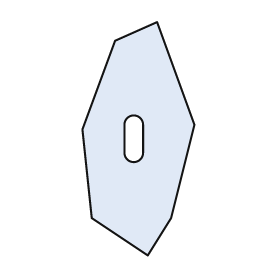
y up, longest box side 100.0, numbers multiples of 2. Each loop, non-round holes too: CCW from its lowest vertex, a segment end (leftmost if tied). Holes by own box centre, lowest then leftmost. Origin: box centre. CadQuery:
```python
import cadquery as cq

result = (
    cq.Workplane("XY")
    .moveTo(4.0, -50.0)
    .lineTo(14.0, -34.0)
    .lineTo(24.0, 6.0)
    .lineTo(8.0, 50.0)
    .lineTo(-10.0, 42.0)
    .lineTo(-24.0, 4.0)
    .lineTo(-20.0, -34.0)
    .close()
    .moveTo(-6.0, -6.0)
    .threePointArc((-2.0, -10.0), (2.0, -6.0))
    .lineTo(2.0, 6.0)
    .threePointArc((-2.0, 10.0), (-6.0, 6.0))
    .close()
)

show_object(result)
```